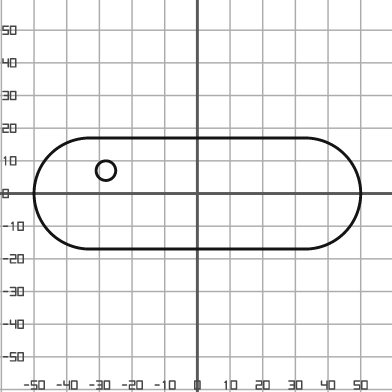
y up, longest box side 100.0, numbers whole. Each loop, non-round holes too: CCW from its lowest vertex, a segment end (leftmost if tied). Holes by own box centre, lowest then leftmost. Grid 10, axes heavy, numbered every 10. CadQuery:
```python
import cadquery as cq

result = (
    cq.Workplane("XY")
    .moveTo(-33.0, -17.0)
    .lineTo(33.0, -17.0)
    .threePointArc((50.0, 0.0), (33.0, 17.0))
    .lineTo(-33.0, 17.0)
    .threePointArc((-50.0, 0.0), (-33.0, -17.0))
    .close()
    .moveTo(-28.0, 7.0)
    .circle(3.0)
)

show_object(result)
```